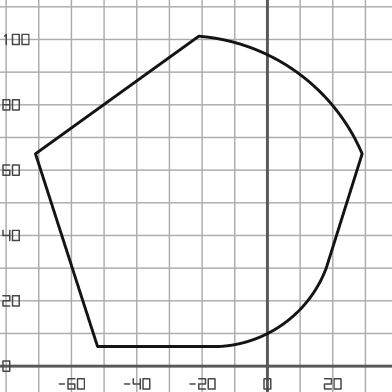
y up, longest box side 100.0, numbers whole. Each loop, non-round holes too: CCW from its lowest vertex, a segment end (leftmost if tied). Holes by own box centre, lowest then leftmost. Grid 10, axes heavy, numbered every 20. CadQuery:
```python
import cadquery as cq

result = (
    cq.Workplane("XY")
    .moveTo(-52.0, 6.0)
    .lineTo(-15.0, 6.0)
    .threePointArc((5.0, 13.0), (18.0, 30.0))
    .lineTo(29.0, 65.0)
    .threePointArc((9.0, 90.0), (-21.0, 101.0))
    .lineTo(-71.0, 65.0)
    .close()
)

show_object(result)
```